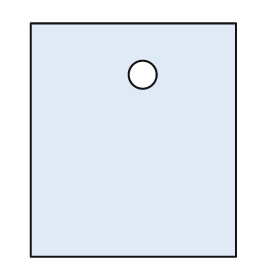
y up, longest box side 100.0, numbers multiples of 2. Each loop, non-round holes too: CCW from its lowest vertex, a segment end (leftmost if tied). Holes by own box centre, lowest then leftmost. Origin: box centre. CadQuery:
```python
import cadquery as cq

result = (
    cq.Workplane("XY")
    .moveTo(-44.0, -50.0)
    .lineTo(44.0, -50.0)
    .lineTo(44.0, 50.0)
    .lineTo(-44.0, 50.0)
    .close()
    .moveTo(4.0, 28.0)
    .circle(6.0)
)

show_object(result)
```